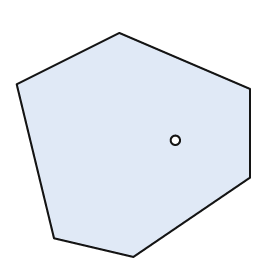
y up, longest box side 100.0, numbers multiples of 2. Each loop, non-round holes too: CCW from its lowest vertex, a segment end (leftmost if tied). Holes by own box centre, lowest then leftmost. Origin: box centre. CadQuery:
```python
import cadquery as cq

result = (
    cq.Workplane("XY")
    .moveTo(0.0, -48.0)
    .lineTo(50.0, -14.0)
    .lineTo(50.0, 24.0)
    .lineTo(-6.0, 48.0)
    .lineTo(-50.0, 26.0)
    .lineTo(-34.0, -40.0)
    .close()
    .moveTo(18.0, 2.0)
    .circle(2.0)
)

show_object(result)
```